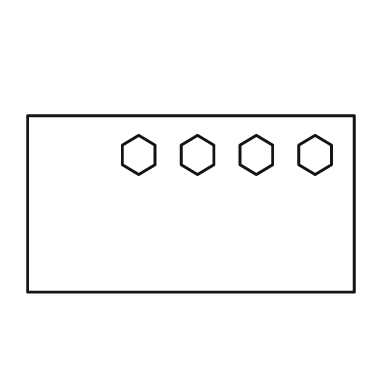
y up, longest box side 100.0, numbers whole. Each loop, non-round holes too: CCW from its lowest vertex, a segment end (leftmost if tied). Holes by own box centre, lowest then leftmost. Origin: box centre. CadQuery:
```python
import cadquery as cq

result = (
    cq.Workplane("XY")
    .moveTo(-50.0, -27.0)
    .lineTo(50.0, -27.0)
    .lineTo(50.0, 27.0)
    .lineTo(-50.0, 27.0)
    .close()
    .moveTo(-16.0, 9.0)
    .lineTo(-11.0, 12.0)
    .lineTo(-11.0, 18.0)
    .lineTo(-16.0, 21.0)
    .lineTo(-21.0, 18.0)
    .lineTo(-21.0, 12.0)
    .close()
    .moveTo(2.0, 9.0)
    .lineTo(7.0, 12.0)
    .lineTo(7.0, 18.0)
    .lineTo(2.0, 21.0)
    .lineTo(-3.0, 18.0)
    .lineTo(-3.0, 12.0)
    .close()
    .moveTo(20.0, 9.0)
    .lineTo(25.0, 12.0)
    .lineTo(25.0, 18.0)
    .lineTo(20.0, 21.0)
    .lineTo(15.0, 18.0)
    .lineTo(15.0, 12.0)
    .close()
    .moveTo(38.0, 9.0)
    .lineTo(43.0, 12.0)
    .lineTo(43.0, 18.0)
    .lineTo(38.0, 21.0)
    .lineTo(33.0, 18.0)
    .lineTo(33.0, 12.0)
    .close()
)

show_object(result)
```